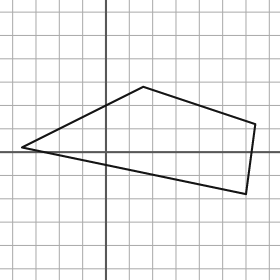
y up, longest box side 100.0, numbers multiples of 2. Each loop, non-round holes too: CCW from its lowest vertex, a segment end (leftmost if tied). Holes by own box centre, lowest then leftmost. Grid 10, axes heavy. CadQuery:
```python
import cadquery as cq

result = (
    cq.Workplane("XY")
    .moveTo(60.0, -18.0)
    .lineTo(64.0, 12.0)
    .lineTo(16.0, 28.0)
    .lineTo(-36.0, 2.0)
    .close()
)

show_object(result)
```